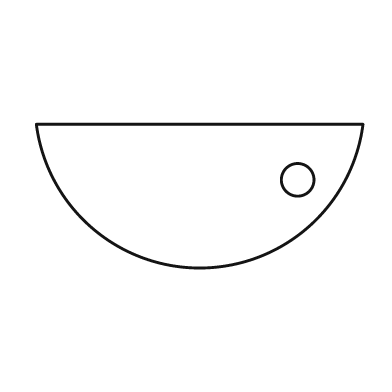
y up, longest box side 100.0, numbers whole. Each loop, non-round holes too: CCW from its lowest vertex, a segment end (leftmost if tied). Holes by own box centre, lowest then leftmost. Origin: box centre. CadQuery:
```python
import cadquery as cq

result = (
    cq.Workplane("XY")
    .moveTo(-50.0, 22.0)
    .threePointArc((0.0, -22.0), (50.0, 22.0))
    .close()
    .moveTo(30.0, 5.0)
    .circle(5.0)
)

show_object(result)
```